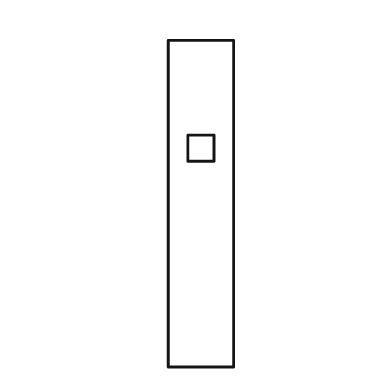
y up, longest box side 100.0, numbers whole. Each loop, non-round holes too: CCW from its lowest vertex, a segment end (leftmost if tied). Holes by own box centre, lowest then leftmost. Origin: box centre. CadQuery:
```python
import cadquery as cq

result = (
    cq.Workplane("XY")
    .moveTo(-10.0, -50.0)
    .lineTo(10.0, -50.0)
    .lineTo(10.0, 50.0)
    .lineTo(-10.0, 50.0)
    .close()
    .moveTo(-4.0, 13.0)
    .lineTo(4.0, 13.0)
    .lineTo(4.0, 21.0)
    .lineTo(-4.0, 21.0)
    .close()
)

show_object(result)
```